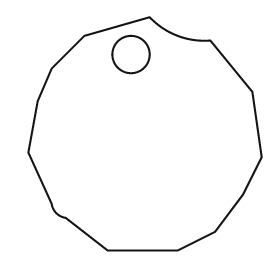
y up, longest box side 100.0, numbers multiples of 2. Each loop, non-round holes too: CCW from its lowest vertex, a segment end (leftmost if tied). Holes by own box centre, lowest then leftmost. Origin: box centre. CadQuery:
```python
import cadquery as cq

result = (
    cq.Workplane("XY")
    .moveTo(-16.0, -50.0)
    .lineTo(14.0, -50.0)
    .lineTo(30.0, -42.0)
    .lineTo(42.0, -26.0)
    .lineTo(50.0, -10.0)
    .lineTo(46.0, 18.0)
    .lineTo(28.0, 40.0)
    .threePointArc((14.0, 42.0), (2.0, 50.0))
    .lineTo(-26.0, 42.0)
    .lineTo(-40.0, 28.0)
    .lineTo(-46.0, 14.0)
    .lineTo(-50.0, -8.0)
    .lineTo(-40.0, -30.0)
    .threePointArc((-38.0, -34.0), (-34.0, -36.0))
    .close()
    .moveTo(-6.0, 34.0)
    .circle(8.0)
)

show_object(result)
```